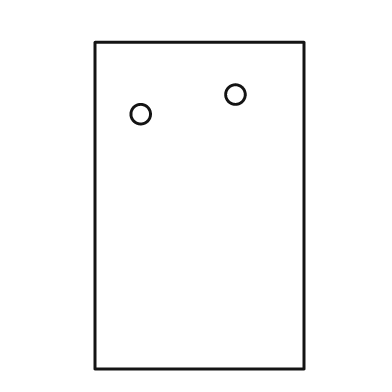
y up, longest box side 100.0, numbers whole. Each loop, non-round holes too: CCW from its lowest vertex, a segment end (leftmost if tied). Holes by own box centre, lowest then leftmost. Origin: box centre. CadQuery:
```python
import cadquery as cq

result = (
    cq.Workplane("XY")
    .moveTo(-32.0, -50.0)
    .lineTo(32.0, -50.0)
    .lineTo(32.0, 50.0)
    .lineTo(-32.0, 50.0)
    .close()
    .moveTo(-18.0, 28.0)
    .circle(3.0)
    .moveTo(11.0, 34.0)
    .circle(3.0)
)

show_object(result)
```